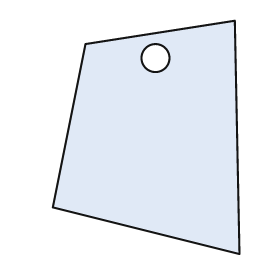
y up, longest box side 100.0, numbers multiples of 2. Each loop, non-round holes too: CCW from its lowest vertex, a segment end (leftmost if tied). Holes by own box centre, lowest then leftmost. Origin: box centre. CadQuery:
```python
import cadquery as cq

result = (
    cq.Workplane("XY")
    .moveTo(40.0, -50.0)
    .lineTo(38.0, 50.0)
    .lineTo(-26.0, 40.0)
    .lineTo(-40.0, -30.0)
    .close()
    .moveTo(4.0, 34.0)
    .circle(6.0)
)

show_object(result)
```